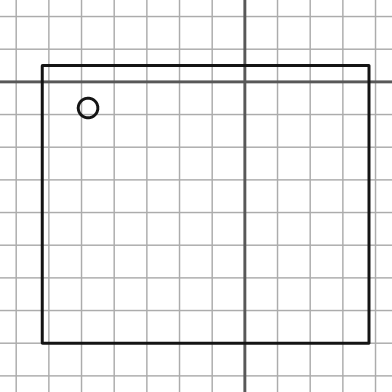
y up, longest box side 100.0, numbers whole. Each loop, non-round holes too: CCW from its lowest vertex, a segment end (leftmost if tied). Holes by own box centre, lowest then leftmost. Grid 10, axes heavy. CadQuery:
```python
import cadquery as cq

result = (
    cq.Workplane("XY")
    .moveTo(-62.0, -80.0)
    .lineTo(38.0, -80.0)
    .lineTo(38.0, 5.0)
    .lineTo(-62.0, 5.0)
    .close()
    .moveTo(-48.0, -8.0)
    .circle(3.0)
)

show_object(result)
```